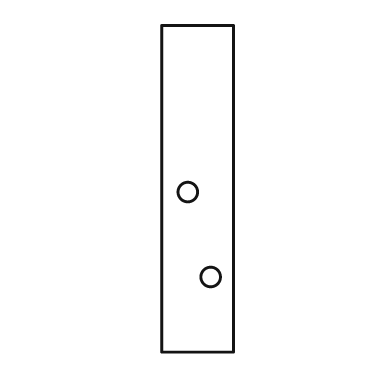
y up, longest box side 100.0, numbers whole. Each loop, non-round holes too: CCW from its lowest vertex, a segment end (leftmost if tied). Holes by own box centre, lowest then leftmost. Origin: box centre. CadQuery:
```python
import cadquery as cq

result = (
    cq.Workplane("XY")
    .moveTo(-11.0, -50.0)
    .lineTo(11.0, -50.0)
    .lineTo(11.0, 50.0)
    .lineTo(-11.0, 50.0)
    .close()
    .moveTo(4.0, -27.0)
    .circle(3.0)
    .moveTo(-3.0, -1.0)
    .circle(3.0)
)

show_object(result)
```